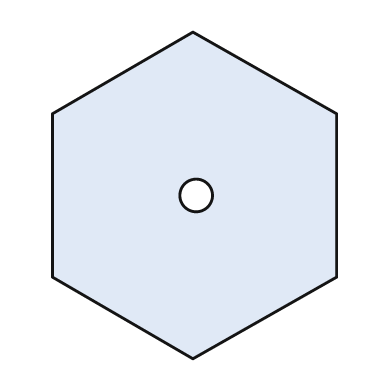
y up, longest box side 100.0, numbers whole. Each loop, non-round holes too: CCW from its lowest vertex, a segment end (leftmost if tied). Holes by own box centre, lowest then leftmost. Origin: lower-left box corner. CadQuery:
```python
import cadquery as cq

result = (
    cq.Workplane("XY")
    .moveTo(43.0, 0.0)
    .lineTo(87.0, 25.0)
    .lineTo(87.0, 75.0)
    .lineTo(43.0, 100.0)
    .lineTo(0.0, 75.0)
    .lineTo(0.0, 25.0)
    .close()
    .moveTo(44.0, 50.0)
    .circle(5.0)
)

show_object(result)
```